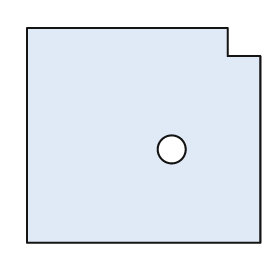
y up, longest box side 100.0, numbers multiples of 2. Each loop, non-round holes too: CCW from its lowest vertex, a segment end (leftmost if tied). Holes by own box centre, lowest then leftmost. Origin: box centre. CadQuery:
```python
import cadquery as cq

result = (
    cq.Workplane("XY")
    .moveTo(-50.0, -46.0)
    .lineTo(50.0, -46.0)
    .lineTo(50.0, 34.0)
    .lineTo(36.0, 34.0)
    .lineTo(36.0, 46.0)
    .lineTo(-50.0, 46.0)
    .close()
    .moveTo(12.0, -6.0)
    .circle(6.0)
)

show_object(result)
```